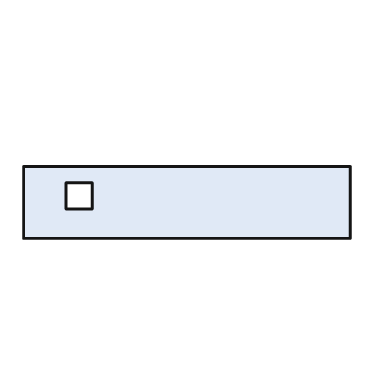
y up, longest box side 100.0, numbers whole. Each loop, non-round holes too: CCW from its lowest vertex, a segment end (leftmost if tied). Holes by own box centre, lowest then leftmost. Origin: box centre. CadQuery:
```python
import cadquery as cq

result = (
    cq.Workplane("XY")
    .moveTo(-50.0, -11.0)
    .lineTo(50.0, -11.0)
    .lineTo(50.0, 11.0)
    .lineTo(-50.0, 11.0)
    .close()
    .moveTo(-37.0, -2.0)
    .lineTo(-29.0, -2.0)
    .lineTo(-29.0, 6.0)
    .lineTo(-37.0, 6.0)
    .close()
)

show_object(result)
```